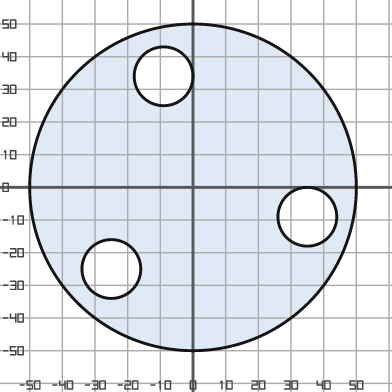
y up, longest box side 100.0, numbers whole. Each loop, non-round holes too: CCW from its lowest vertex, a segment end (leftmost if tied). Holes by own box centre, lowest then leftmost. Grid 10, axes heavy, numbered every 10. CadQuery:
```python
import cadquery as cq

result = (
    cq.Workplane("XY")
    .moveTo(0.0, 0.0)
    .circle(50.0)
    .moveTo(-25.0, -25.0)
    .circle(9.0)
    .moveTo(35.0, -9.0)
    .circle(9.0)
    .moveTo(-9.0, 34.0)
    .circle(9.0)
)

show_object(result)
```